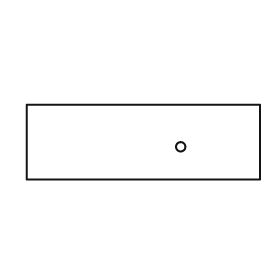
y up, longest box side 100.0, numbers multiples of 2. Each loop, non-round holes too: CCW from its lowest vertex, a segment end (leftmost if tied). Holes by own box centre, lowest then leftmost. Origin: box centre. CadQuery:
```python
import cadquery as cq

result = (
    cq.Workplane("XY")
    .moveTo(-50.0, -16.0)
    .lineTo(50.0, -16.0)
    .lineTo(50.0, 16.0)
    .lineTo(-50.0, 16.0)
    .close()
    .moveTo(16.0, -2.0)
    .circle(2.0)
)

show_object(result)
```